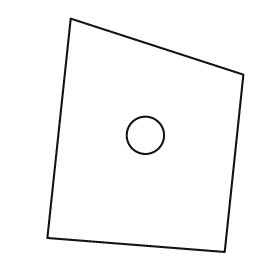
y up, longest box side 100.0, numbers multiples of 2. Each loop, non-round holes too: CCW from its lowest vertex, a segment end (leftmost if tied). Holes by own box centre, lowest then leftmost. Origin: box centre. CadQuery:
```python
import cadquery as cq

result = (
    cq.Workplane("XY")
    .moveTo(34.0, -50.0)
    .lineTo(42.0, 26.0)
    .lineTo(-32.0, 50.0)
    .lineTo(-42.0, -44.0)
    .close()
    .moveTo(0.0, 0.0)
    .circle(8.0)
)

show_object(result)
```